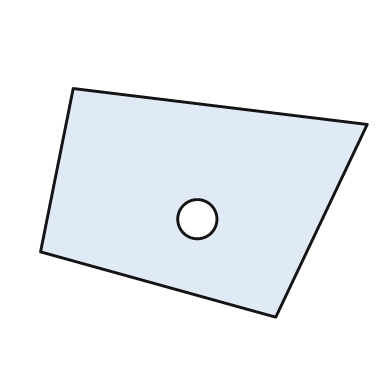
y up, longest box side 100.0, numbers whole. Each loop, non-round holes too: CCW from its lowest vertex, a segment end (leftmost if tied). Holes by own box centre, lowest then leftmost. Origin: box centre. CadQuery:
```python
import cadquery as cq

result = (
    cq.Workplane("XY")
    .moveTo(22.0, -35.0)
    .lineTo(50.0, 24.0)
    .lineTo(-40.0, 35.0)
    .lineTo(-50.0, -15.0)
    .close()
    .moveTo(-2.0, -5.0)
    .circle(6.0)
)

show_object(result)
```